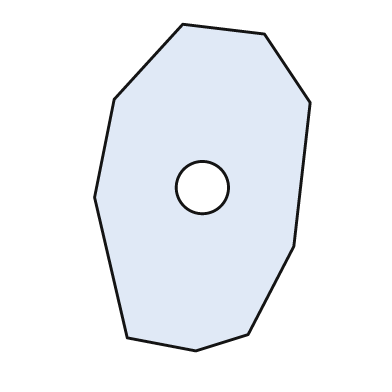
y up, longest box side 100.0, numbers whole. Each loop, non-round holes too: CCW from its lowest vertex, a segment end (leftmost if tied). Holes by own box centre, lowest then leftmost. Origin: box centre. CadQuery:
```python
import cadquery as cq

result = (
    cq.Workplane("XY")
    .moveTo(-2.0, -50.0)
    .lineTo(14.0, -45.0)
    .lineTo(28.0, -18.0)
    .lineTo(33.0, 26.0)
    .lineTo(19.0, 47.0)
    .lineTo(-6.0, 50.0)
    .lineTo(-27.0, 27.0)
    .lineTo(-33.0, -3.0)
    .lineTo(-23.0, -46.0)
    .close()
    .moveTo(0.0, 0.0)
    .circle(8.0)
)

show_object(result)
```